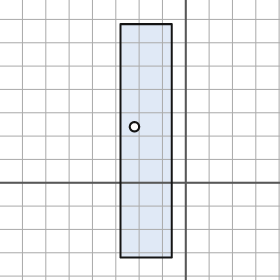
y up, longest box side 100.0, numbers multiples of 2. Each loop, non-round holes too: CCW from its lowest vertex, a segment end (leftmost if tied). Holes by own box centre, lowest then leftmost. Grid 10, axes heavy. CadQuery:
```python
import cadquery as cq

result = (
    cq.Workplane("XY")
    .moveTo(-28.0, -32.0)
    .lineTo(-6.0, -32.0)
    .lineTo(-6.0, 68.0)
    .lineTo(-28.0, 68.0)
    .close()
    .moveTo(-22.0, 24.0)
    .circle(2.0)
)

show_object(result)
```